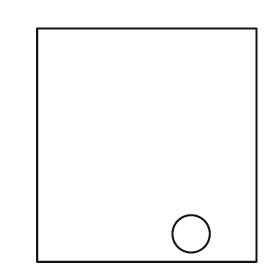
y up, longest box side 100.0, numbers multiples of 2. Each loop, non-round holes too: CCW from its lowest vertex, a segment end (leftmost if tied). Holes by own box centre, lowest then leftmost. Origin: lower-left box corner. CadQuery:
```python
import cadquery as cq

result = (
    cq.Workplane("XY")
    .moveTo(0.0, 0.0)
    .lineTo(94.0, 0.0)
    .lineTo(94.0, 100.0)
    .lineTo(0.0, 100.0)
    .close()
    .moveTo(66.0, 12.0)
    .circle(8.0)
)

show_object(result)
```